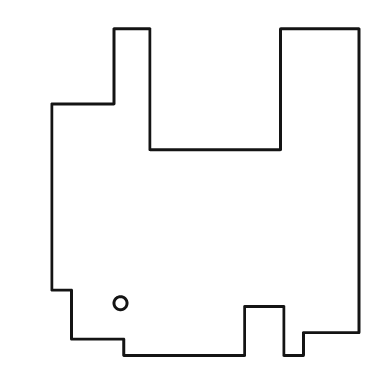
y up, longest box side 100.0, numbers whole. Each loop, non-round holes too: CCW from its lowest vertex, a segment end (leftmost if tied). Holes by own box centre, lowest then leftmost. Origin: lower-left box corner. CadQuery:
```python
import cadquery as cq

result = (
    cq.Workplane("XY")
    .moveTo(22.0, 0.0)
    .lineTo(59.0, 0.0)
    .lineTo(59.0, 15.0)
    .lineTo(71.0, 15.0)
    .lineTo(71.0, 0.0)
    .lineTo(77.0, 0.0)
    .lineTo(77.0, 7.0)
    .lineTo(94.0, 7.0)
    .lineTo(94.0, 100.0)
    .lineTo(70.0, 100.0)
    .lineTo(70.0, 63.0)
    .lineTo(30.0, 63.0)
    .lineTo(30.0, 100.0)
    .lineTo(19.0, 100.0)
    .lineTo(19.0, 77.0)
    .lineTo(0.0, 77.0)
    .lineTo(0.0, 20.0)
    .lineTo(6.0, 20.0)
    .lineTo(6.0, 5.0)
    .lineTo(22.0, 5.0)
    .close()
    .moveTo(21.0, 16.0)
    .circle(2.0)
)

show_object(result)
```